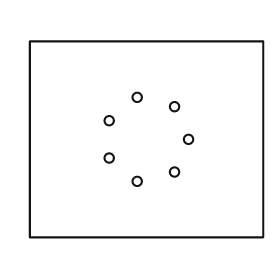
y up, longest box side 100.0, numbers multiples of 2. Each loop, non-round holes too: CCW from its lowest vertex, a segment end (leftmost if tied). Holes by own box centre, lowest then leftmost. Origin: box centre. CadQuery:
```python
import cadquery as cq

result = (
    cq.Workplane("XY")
    .moveTo(-50.0, -42.0)
    .lineTo(50.0, -42.0)
    .lineTo(50.0, 42.0)
    .lineTo(-50.0, 42.0)
    .close()
    .moveTo(-4.0, -18.0)
    .circle(2.0)
    .moveTo(12.0, -14.0)
    .circle(2.0)
    .moveTo(-16.0, -8.0)
    .circle(2.0)
    .moveTo(18.0, 0.0)
    .circle(2.0)
    .moveTo(-16.0, 8.0)
    .circle(2.0)
    .moveTo(12.0, 14.0)
    .circle(2.0)
    .moveTo(-4.0, 18.0)
    .circle(2.0)
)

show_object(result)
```